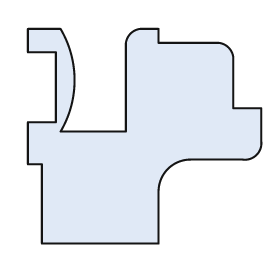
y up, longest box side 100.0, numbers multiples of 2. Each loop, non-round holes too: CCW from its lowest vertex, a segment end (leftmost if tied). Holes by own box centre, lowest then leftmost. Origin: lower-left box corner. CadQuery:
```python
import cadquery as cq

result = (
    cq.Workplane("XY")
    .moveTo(6.0, 0.0)
    .lineTo(56.0, 0.0)
    .lineTo(56.0, 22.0)
    .threePointArc((60.0, 32.0), (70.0, 36.0))
    .lineTo(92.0, 36.0)
    .threePointArc((98.0, 38.0), (100.0, 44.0))
    .lineTo(100.0, 58.0)
    .lineTo(88.0, 58.0)
    .lineTo(88.0, 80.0)
    .threePointArc((86.0, 84.0), (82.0, 86.0))
    .lineTo(56.0, 86.0)
    .lineTo(56.0, 92.0)
    .lineTo(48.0, 92.0)
    .threePointArc((44.0, 90.0), (42.0, 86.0))
    .lineTo(42.0, 48.0)
    .lineTo(14.0, 48.0)
    .threePointArc((20.0, 70.0), (14.0, 92.0))
    .lineTo(0.0, 92.0)
    .lineTo(0.0, 82.0)
    .lineTo(12.0, 82.0)
    .lineTo(12.0, 52.0)
    .lineTo(0.0, 52.0)
    .lineTo(0.0, 34.0)
    .lineTo(6.0, 34.0)
    .close()
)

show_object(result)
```